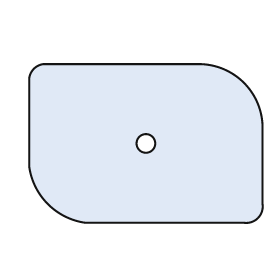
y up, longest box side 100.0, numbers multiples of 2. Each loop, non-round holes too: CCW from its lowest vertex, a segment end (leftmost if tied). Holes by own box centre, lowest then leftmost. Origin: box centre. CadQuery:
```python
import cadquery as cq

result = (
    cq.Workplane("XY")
    .moveTo(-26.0, -34.0)
    .lineTo(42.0, -34.0)
    .threePointArc((48.0, -32.0), (50.0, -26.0))
    .lineTo(50.0, 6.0)
    .threePointArc((42.0, 26.0), (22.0, 34.0))
    .lineTo(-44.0, 34.0)
    .threePointArc((-48.0, 32.0), (-50.0, 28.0))
    .lineTo(-50.0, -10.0)
    .threePointArc((-42.0, -26.0), (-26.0, -34.0))
    .close()
    .moveTo(0.0, 0.0)
    .circle(4.0)
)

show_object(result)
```